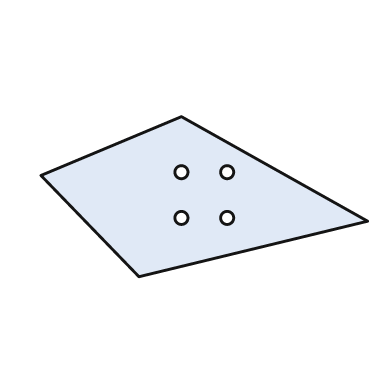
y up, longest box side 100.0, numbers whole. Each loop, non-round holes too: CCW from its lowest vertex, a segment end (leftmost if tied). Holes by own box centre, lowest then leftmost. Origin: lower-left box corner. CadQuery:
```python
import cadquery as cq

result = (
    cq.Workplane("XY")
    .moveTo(30.0, 0.0)
    .lineTo(100.0, 17.0)
    .lineTo(43.0, 49.0)
    .lineTo(0.0, 31.0)
    .close()
    .moveTo(43.0, 18.0)
    .circle(2.0)
    .moveTo(57.0, 18.0)
    .circle(2.0)
    .moveTo(43.0, 32.0)
    .circle(2.0)
    .moveTo(57.0, 32.0)
    .circle(2.0)
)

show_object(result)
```